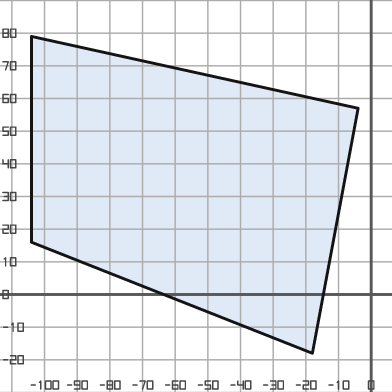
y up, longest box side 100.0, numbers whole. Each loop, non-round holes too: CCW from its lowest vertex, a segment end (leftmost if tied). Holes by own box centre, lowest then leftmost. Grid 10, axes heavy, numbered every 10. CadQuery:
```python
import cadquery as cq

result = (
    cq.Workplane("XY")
    .moveTo(-18.0, -18.0)
    .lineTo(-4.0, 57.0)
    .lineTo(-104.0, 79.0)
    .lineTo(-104.0, 16.0)
    .close()
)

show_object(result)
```